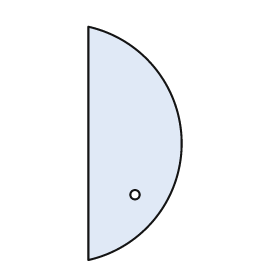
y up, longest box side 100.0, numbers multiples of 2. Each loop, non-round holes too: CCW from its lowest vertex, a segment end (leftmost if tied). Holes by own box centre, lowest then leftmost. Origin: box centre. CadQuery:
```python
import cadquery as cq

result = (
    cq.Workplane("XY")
    .moveTo(-20.0, -50.0)
    .threePointArc((20.0, 0.0), (-20.0, 50.0))
    .close()
    .moveTo(0.0, -22.0)
    .circle(2.0)
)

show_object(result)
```